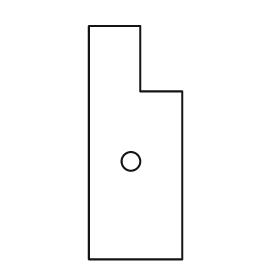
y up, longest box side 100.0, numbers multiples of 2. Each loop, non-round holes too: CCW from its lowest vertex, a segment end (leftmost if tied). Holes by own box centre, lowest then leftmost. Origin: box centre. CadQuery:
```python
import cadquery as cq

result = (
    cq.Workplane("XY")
    .moveTo(-20.0, -50.0)
    .lineTo(20.0, -50.0)
    .lineTo(20.0, 22.0)
    .lineTo(2.0, 22.0)
    .lineTo(2.0, 50.0)
    .lineTo(-20.0, 50.0)
    .close()
    .moveTo(-2.0, -8.0)
    .circle(4.0)
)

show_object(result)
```